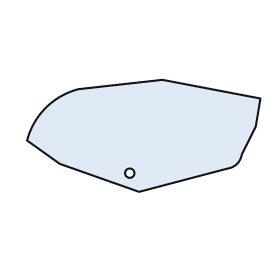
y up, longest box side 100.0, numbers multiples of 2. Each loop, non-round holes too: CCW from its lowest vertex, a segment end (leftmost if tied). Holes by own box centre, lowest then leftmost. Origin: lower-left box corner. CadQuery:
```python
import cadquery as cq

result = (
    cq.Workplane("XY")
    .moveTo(48.0, 0.0)
    .lineTo(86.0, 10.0)
    .threePointArc((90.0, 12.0), (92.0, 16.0))
    .lineTo(98.0, 28.0)
    .lineTo(100.0, 40.0)
    .lineTo(58.0, 48.0)
    .lineTo(22.0, 44.0)
    .threePointArc((8.0, 36.0), (0.0, 22.0))
    .lineTo(14.0, 12.0)
    .close()
    .moveTo(44.0, 8.0)
    .circle(2.0)
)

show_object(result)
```